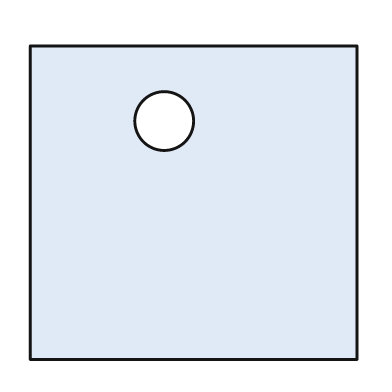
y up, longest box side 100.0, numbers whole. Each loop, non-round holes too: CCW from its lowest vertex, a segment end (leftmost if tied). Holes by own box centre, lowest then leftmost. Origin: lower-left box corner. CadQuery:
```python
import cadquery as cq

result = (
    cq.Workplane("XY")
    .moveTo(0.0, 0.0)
    .lineTo(100.0, 0.0)
    .lineTo(100.0, 96.0)
    .lineTo(0.0, 96.0)
    .close()
    .moveTo(41.0, 73.0)
    .circle(9.0)
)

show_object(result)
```